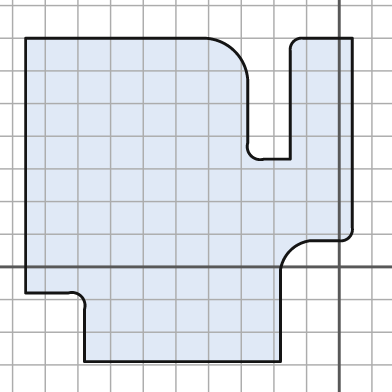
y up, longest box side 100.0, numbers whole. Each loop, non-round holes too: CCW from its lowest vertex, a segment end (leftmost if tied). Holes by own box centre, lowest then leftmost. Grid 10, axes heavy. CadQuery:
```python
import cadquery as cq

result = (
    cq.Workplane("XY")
    .moveTo(-78.0, -29.0)
    .lineTo(-18.0, -29.0)
    .lineTo(-18.0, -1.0)
    .threePointArc((-15.0, 5.0), (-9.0, 8.0))
    .lineTo(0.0, 8.0)
    .threePointArc((3.0, 9.0), (4.0, 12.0))
    .lineTo(4.0, 70.0)
    .lineTo(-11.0, 70.0)
    .threePointArc((-14.0, 69.0), (-15.0, 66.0))
    .lineTo(-15.0, 33.0)
    .lineTo(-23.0, 33.0)
    .threePointArc((-27.0, 34.0), (-28.0, 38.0))
    .lineTo(-28.0, 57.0)
    .threePointArc((-32.0, 66.0), (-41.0, 70.0))
    .lineTo(-96.0, 70.0)
    .lineTo(-96.0, -8.0)
    .lineTo(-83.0, -8.0)
    .threePointArc((-79.0, -9.0), (-78.0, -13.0))
    .close()
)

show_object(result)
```